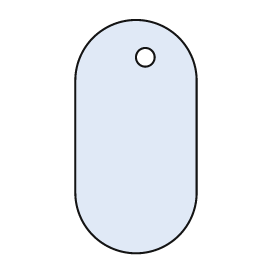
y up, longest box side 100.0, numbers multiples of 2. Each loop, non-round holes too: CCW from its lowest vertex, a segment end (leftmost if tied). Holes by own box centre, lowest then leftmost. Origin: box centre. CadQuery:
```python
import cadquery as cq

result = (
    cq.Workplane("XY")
    .moveTo(-26.0, -24.0)
    .threePointArc((0.0, -50.0), (26.0, -24.0))
    .lineTo(26.0, 24.0)
    .threePointArc((0.0, 50.0), (-26.0, 24.0))
    .close()
    .moveTo(4.0, 34.0)
    .circle(4.0)
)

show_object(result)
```